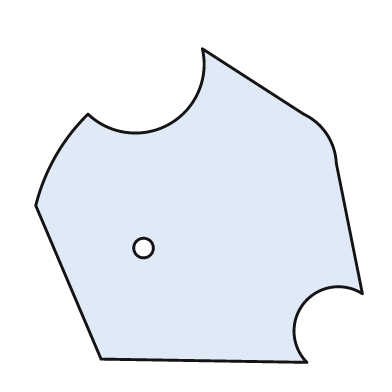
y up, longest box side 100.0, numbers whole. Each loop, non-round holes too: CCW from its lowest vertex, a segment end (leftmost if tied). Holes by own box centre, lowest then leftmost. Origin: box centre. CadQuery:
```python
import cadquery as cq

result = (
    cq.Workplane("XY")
    .moveTo(33.0, -48.0)
    .threePointArc((32.0, -30.0), (50.0, -27.0))
    .lineTo(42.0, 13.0)
    .threePointArc((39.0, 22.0), (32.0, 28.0))
    .lineTo(1.0, 48.0)
    .threePointArc((-9.0, 25.0), (-34.0, 28.0))
    .threePointArc((-44.0, 15.0), (-50.0, 0.0))
    .lineTo(-30.0, -47.0)
    .close()
    .moveTo(-17.0, -13.0)
    .circle(3.0)
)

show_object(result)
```